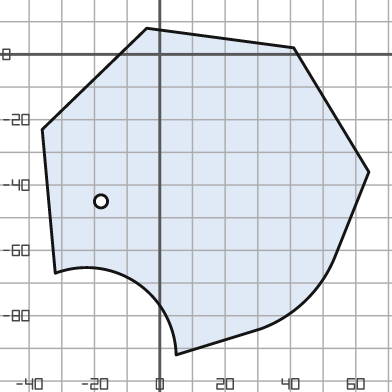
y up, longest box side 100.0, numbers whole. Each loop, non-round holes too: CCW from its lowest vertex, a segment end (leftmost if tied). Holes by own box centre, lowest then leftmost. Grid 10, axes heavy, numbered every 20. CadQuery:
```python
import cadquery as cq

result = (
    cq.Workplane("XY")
    .moveTo(5.0, -92.0)
    .lineTo(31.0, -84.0)
    .threePointArc((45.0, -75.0), (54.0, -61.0))
    .lineTo(64.0, -36.0)
    .lineTo(41.0, 2.0)
    .lineTo(-4.0, 8.0)
    .lineTo(-36.0, -23.0)
    .lineTo(-32.0, -67.0)
    .threePointArc((-7.0, -70.0), (5.0, -92.0))
    .close()
    .moveTo(-18.0, -45.0)
    .circle(2.0)
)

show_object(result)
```